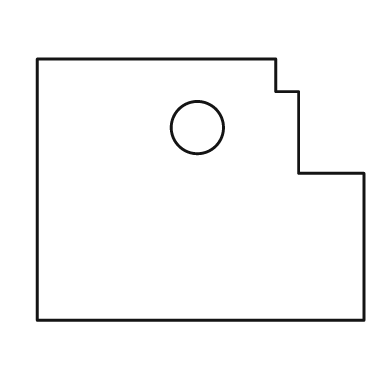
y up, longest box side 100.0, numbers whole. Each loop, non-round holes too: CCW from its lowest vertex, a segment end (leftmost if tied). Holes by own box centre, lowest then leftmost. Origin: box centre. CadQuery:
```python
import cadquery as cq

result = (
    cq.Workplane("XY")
    .moveTo(-50.0, -40.0)
    .lineTo(50.0, -40.0)
    .lineTo(50.0, 5.0)
    .lineTo(30.0, 5.0)
    .lineTo(30.0, 30.0)
    .lineTo(23.0, 30.0)
    .lineTo(23.0, 40.0)
    .lineTo(-50.0, 40.0)
    .close()
    .moveTo(-1.0, 19.0)
    .circle(8.0)
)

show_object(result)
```